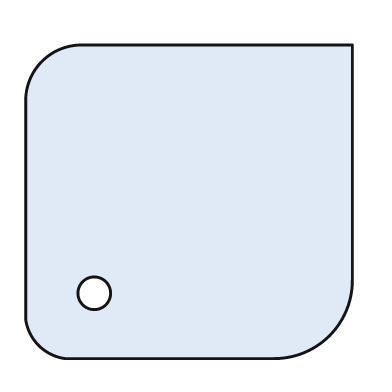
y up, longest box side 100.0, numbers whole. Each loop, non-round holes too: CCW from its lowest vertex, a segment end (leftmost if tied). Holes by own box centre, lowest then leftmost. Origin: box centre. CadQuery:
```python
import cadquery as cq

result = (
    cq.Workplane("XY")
    .moveTo(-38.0, -48.0)
    .lineTo(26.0, -48.0)
    .threePointArc((43.0, -41.0), (50.0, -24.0))
    .lineTo(50.0, 48.0)
    .lineTo(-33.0, 48.0)
    .threePointArc((-45.0, 43.0), (-50.0, 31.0))
    .lineTo(-50.0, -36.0)
    .threePointArc((-46.0, -44.0), (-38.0, -48.0))
    .close()
    .moveTo(-29.0, -28.0)
    .circle(5.0)
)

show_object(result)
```